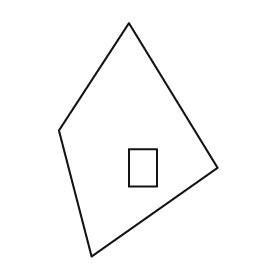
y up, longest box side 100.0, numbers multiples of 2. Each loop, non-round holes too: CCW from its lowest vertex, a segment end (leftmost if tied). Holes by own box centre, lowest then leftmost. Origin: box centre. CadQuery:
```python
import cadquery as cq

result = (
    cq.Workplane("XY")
    .moveTo(-20.0, -50.0)
    .lineTo(34.0, -12.0)
    .lineTo(-4.0, 50.0)
    .lineTo(-34.0, 4.0)
    .close()
    .moveTo(-4.0, -20.0)
    .lineTo(8.0, -20.0)
    .lineTo(8.0, -4.0)
    .lineTo(-4.0, -4.0)
    .close()
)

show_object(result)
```